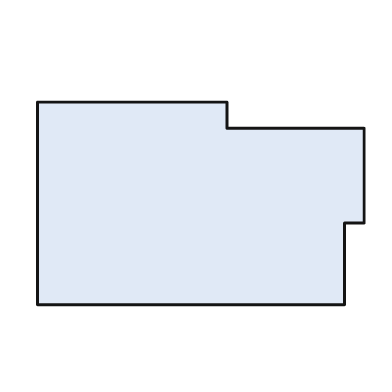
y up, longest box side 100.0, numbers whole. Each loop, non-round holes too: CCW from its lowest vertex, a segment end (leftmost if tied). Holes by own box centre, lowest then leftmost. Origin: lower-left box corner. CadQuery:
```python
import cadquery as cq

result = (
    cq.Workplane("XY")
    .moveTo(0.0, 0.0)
    .lineTo(94.0, 0.0)
    .lineTo(94.0, 25.0)
    .lineTo(100.0, 25.0)
    .lineTo(100.0, 54.0)
    .lineTo(58.0, 54.0)
    .lineTo(58.0, 62.0)
    .lineTo(0.0, 62.0)
    .close()
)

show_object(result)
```